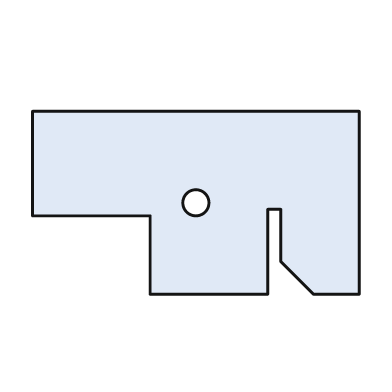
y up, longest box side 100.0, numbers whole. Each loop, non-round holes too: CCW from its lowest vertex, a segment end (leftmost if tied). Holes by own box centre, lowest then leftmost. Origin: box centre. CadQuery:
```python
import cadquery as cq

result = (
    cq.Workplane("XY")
    .moveTo(-14.0, -28.0)
    .lineTo(22.0, -28.0)
    .lineTo(22.0, -2.0)
    .lineTo(26.0, -2.0)
    .lineTo(26.0, -18.0)
    .lineTo(36.0, -28.0)
    .lineTo(50.0, -28.0)
    .lineTo(50.0, 28.0)
    .lineTo(-50.0, 28.0)
    .lineTo(-50.0, -4.0)
    .lineTo(-14.0, -4.0)
    .close()
    .moveTo(0.0, 0.0)
    .circle(4.0)
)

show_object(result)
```